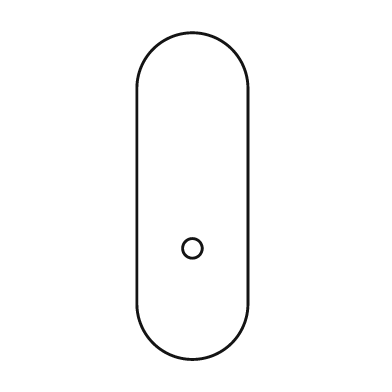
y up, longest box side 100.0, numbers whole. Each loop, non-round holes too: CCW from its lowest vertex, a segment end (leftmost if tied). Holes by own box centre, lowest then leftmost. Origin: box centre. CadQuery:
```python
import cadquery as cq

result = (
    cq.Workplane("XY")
    .moveTo(-17.0, -33.0)
    .threePointArc((0.0, -50.0), (17.0, -33.0))
    .lineTo(17.0, 33.0)
    .threePointArc((0.0, 50.0), (-17.0, 33.0))
    .close()
    .moveTo(0.0, -16.0)
    .circle(3.0)
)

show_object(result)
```